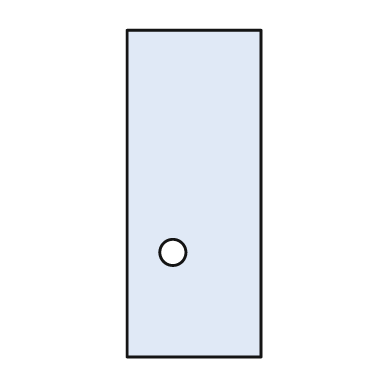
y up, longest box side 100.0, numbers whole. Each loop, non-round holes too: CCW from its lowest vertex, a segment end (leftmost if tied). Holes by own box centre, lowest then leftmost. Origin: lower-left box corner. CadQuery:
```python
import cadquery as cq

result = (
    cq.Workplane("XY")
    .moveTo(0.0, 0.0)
    .lineTo(41.0, 0.0)
    .lineTo(41.0, 100.0)
    .lineTo(0.0, 100.0)
    .close()
    .moveTo(14.0, 32.0)
    .circle(4.0)
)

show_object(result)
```